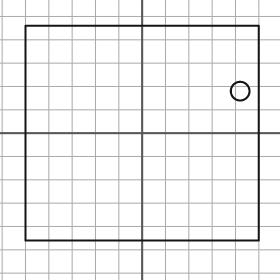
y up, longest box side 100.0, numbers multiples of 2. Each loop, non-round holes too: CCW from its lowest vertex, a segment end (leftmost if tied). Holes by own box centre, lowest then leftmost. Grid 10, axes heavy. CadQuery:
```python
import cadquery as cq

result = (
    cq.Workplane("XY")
    .moveTo(-50.0, -46.0)
    .lineTo(50.0, -46.0)
    .lineTo(50.0, 46.0)
    .lineTo(-50.0, 46.0)
    .close()
    .moveTo(42.0, 18.0)
    .circle(4.0)
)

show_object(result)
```